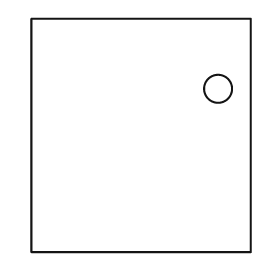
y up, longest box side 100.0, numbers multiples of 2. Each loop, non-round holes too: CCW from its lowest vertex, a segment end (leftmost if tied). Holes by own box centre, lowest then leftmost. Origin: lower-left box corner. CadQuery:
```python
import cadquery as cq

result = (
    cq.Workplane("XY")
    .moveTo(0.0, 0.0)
    .lineTo(94.0, 0.0)
    .lineTo(94.0, 100.0)
    .lineTo(0.0, 100.0)
    .close()
    .moveTo(80.0, 70.0)
    .circle(6.0)
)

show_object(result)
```